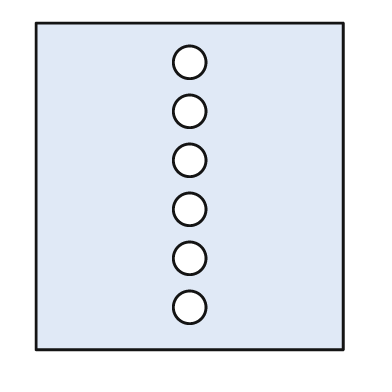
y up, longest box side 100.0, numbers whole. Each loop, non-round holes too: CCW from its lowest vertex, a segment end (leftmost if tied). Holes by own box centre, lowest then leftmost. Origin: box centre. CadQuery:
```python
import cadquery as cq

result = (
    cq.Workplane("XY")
    .moveTo(-47.0, -50.0)
    .lineTo(47.0, -50.0)
    .lineTo(47.0, 50.0)
    .lineTo(-47.0, 50.0)
    .close()
    .moveTo(0.0, -37.0)
    .circle(5.0)
    .moveTo(0.0, -22.0)
    .circle(5.0)
    .moveTo(0.0, -7.0)
    .circle(5.0)
    .moveTo(0.0, 8.0)
    .circle(5.0)
    .moveTo(0.0, 23.0)
    .circle(5.0)
    .moveTo(0.0, 38.0)
    .circle(5.0)
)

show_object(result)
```